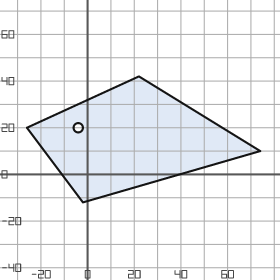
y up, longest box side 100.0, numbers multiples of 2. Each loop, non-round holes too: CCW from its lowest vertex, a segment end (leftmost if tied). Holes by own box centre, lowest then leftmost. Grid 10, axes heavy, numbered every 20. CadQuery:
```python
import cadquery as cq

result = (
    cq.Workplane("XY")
    .moveTo(-2.0, -12.0)
    .lineTo(74.0, 10.0)
    .lineTo(22.0, 42.0)
    .lineTo(-26.0, 20.0)
    .close()
    .moveTo(-4.0, 20.0)
    .circle(2.0)
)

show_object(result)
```